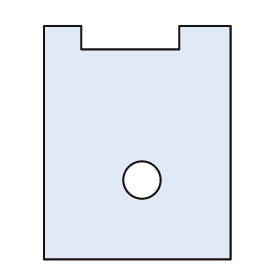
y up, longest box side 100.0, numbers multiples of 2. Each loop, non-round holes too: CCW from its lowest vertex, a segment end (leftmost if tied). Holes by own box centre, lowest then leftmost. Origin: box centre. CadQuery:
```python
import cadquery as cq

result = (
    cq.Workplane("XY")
    .moveTo(-40.0, -50.0)
    .lineTo(40.0, -50.0)
    .lineTo(40.0, 50.0)
    .lineTo(18.0, 50.0)
    .lineTo(18.0, 40.0)
    .lineTo(-24.0, 40.0)
    .lineTo(-24.0, 50.0)
    .lineTo(-40.0, 50.0)
    .close()
    .moveTo(2.0, -16.0)
    .circle(8.0)
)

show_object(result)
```